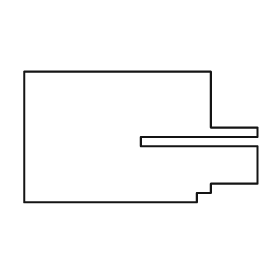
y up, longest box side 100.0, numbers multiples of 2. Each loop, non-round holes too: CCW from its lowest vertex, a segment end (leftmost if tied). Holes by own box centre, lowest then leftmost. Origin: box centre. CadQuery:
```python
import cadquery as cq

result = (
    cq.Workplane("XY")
    .moveTo(-50.0, -28.0)
    .lineTo(24.0, -28.0)
    .lineTo(24.0, -24.0)
    .lineTo(30.0, -24.0)
    .lineTo(30.0, -20.0)
    .lineTo(50.0, -20.0)
    .lineTo(50.0, -4.0)
    .lineTo(0.0, -4.0)
    .lineTo(0.0, 0.0)
    .lineTo(50.0, 0.0)
    .lineTo(50.0, 4.0)
    .lineTo(30.0, 4.0)
    .lineTo(30.0, 28.0)
    .lineTo(-50.0, 28.0)
    .close()
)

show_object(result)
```